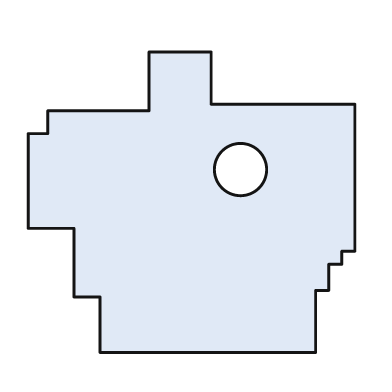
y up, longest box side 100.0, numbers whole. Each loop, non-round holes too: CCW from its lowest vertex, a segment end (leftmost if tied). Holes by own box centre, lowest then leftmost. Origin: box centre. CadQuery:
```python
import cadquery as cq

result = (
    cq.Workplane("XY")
    .moveTo(-28.0, -46.0)
    .lineTo(38.0, -46.0)
    .lineTo(38.0, -27.0)
    .lineTo(42.0, -27.0)
    .lineTo(42.0, -19.0)
    .lineTo(46.0, -19.0)
    .lineTo(46.0, -15.0)
    .lineTo(50.0, -15.0)
    .lineTo(50.0, 30.0)
    .lineTo(6.0, 30.0)
    .lineTo(6.0, 46.0)
    .lineTo(-13.0, 46.0)
    .lineTo(-13.0, 28.0)
    .lineTo(-44.0, 28.0)
    .lineTo(-44.0, 21.0)
    .lineTo(-50.0, 21.0)
    .lineTo(-50.0, -8.0)
    .lineTo(-36.0, -8.0)
    .lineTo(-36.0, -29.0)
    .lineTo(-28.0, -29.0)
    .close()
    .moveTo(15.0, 10.0)
    .circle(8.0)
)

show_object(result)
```